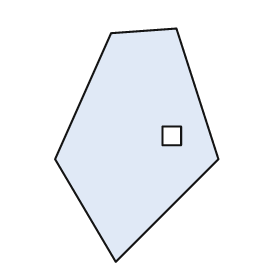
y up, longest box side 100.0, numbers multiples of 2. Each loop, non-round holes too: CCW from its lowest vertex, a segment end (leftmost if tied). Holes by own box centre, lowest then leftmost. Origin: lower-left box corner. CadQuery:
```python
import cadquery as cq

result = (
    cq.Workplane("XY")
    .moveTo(26.0, 0.0)
    .lineTo(70.0, 44.0)
    .lineTo(52.0, 100.0)
    .lineTo(24.0, 98.0)
    .lineTo(0.0, 44.0)
    .close()
    .moveTo(46.0, 50.0)
    .lineTo(54.0, 50.0)
    .lineTo(54.0, 58.0)
    .lineTo(46.0, 58.0)
    .close()
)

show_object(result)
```